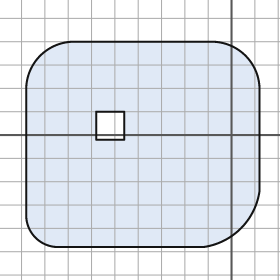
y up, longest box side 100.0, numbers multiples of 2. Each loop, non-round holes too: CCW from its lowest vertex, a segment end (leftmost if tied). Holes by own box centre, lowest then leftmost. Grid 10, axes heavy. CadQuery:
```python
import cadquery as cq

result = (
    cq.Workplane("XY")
    .moveTo(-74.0, -48.0)
    .lineTo(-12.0, -48.0)
    .threePointArc((4.0, -40.0), (12.0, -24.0))
    .lineTo(12.0, 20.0)
    .threePointArc((6.0, 34.0), (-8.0, 40.0))
    .lineTo(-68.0, 40.0)
    .threePointArc((-82.0, 34.0), (-88.0, 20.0))
    .lineTo(-88.0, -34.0)
    .threePointArc((-84.0, -44.0), (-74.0, -48.0))
    .close()
    .moveTo(-58.0, -2.0)
    .lineTo(-46.0, -2.0)
    .lineTo(-46.0, 10.0)
    .lineTo(-58.0, 10.0)
    .close()
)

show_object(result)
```